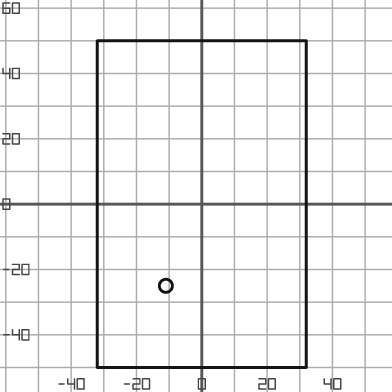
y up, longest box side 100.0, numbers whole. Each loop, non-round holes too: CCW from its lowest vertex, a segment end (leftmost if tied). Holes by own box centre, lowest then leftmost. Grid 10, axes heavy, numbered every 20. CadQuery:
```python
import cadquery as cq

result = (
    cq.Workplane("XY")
    .moveTo(-32.0, -50.0)
    .lineTo(32.0, -50.0)
    .lineTo(32.0, 50.0)
    .lineTo(-32.0, 50.0)
    .close()
    .moveTo(-11.0, -25.0)
    .circle(2.0)
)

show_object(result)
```